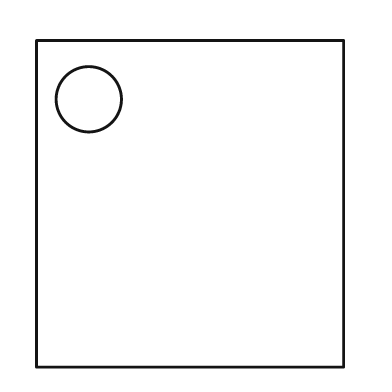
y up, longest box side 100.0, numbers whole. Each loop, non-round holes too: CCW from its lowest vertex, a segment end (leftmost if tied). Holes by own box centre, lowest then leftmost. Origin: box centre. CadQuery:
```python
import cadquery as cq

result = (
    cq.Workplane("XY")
    .moveTo(-47.0, -50.0)
    .lineTo(47.0, -50.0)
    .lineTo(47.0, 50.0)
    .lineTo(-47.0, 50.0)
    .close()
    .moveTo(-31.0, 32.0)
    .circle(10.0)
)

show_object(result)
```